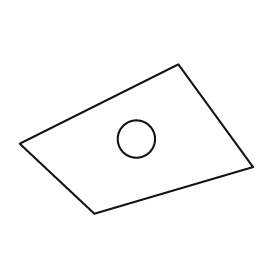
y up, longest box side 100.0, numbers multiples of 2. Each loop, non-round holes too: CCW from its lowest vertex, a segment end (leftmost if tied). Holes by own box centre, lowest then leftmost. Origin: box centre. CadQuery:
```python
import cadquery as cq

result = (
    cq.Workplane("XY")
    .moveTo(-18.0, -32.0)
    .lineTo(50.0, -12.0)
    .lineTo(18.0, 32.0)
    .lineTo(-50.0, -2.0)
    .close()
    .moveTo(0.0, 0.0)
    .circle(8.0)
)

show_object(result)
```